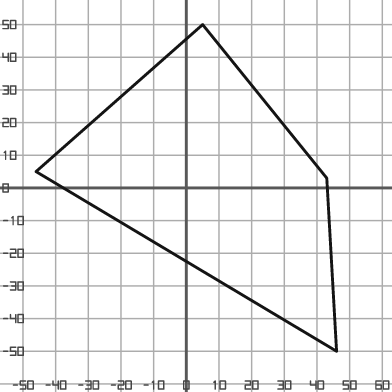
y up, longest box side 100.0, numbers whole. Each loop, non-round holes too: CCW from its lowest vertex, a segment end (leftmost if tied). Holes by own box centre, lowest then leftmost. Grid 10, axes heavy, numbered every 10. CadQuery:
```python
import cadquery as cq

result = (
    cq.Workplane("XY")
    .moveTo(46.0, -50.0)
    .lineTo(43.0, 3.0)
    .lineTo(5.0, 50.0)
    .lineTo(-46.0, 5.0)
    .close()
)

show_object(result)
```